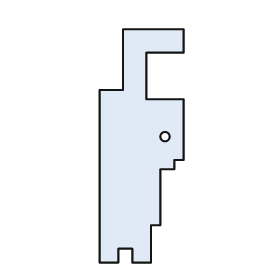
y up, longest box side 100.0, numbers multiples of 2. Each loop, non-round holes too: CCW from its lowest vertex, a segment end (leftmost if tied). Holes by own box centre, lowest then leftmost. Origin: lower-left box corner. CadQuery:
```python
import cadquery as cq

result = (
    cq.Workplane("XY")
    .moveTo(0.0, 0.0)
    .lineTo(8.0, 0.0)
    .lineTo(8.0, 6.0)
    .lineTo(14.0, 6.0)
    .lineTo(14.0, 0.0)
    .lineTo(22.0, 0.0)
    .lineTo(22.0, 16.0)
    .lineTo(26.0, 16.0)
    .lineTo(26.0, 40.0)
    .lineTo(32.0, 40.0)
    .lineTo(32.0, 44.0)
    .lineTo(36.0, 44.0)
    .lineTo(36.0, 70.0)
    .lineTo(20.0, 70.0)
    .lineTo(20.0, 90.0)
    .lineTo(36.0, 90.0)
    .lineTo(36.0, 100.0)
    .lineTo(10.0, 100.0)
    .lineTo(10.0, 74.0)
    .lineTo(0.0, 74.0)
    .close()
    .moveTo(28.0, 54.0)
    .circle(2.0)
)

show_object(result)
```